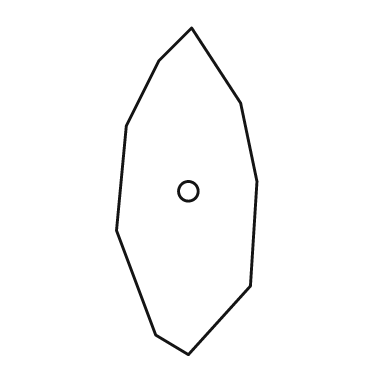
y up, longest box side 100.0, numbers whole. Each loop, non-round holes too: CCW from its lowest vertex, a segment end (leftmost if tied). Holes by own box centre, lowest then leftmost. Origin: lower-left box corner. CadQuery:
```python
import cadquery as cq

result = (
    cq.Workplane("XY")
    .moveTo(22.0, 0.0)
    .lineTo(41.0, 21.0)
    .lineTo(43.0, 53.0)
    .lineTo(38.0, 77.0)
    .lineTo(23.0, 100.0)
    .lineTo(13.0, 90.0)
    .lineTo(3.0, 70.0)
    .lineTo(0.0, 38.0)
    .lineTo(12.0, 6.0)
    .close()
    .moveTo(22.0, 50.0)
    .circle(3.0)
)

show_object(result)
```